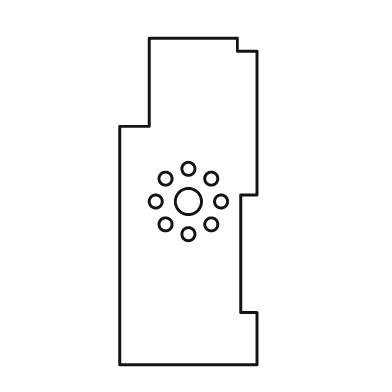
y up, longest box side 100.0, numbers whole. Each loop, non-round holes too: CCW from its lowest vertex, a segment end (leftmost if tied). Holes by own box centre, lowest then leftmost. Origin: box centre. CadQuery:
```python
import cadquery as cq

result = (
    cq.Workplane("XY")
    .moveTo(-21.0, -50.0)
    .lineTo(21.0, -50.0)
    .lineTo(21.0, -34.0)
    .lineTo(16.0, -34.0)
    .lineTo(16.0, 2.0)
    .lineTo(21.0, 2.0)
    .lineTo(21.0, 46.0)
    .lineTo(15.0, 46.0)
    .lineTo(15.0, 50.0)
    .lineTo(-12.0, 50.0)
    .lineTo(-12.0, 23.0)
    .lineTo(-21.0, 23.0)
    .close()
    .moveTo(0.0, -10.0)
    .circle(2.0)
    .moveTo(-7.0, -7.0)
    .circle(2.0)
    .moveTo(7.0, -7.0)
    .circle(2.0)
    .moveTo(-10.0, 0.0)
    .circle(2.0)
    .moveTo(0.0, 0.0)
    .circle(4.0)
    .moveTo(10.0, 0.0)
    .circle(2.0)
    .moveTo(-7.0, 7.0)
    .circle(2.0)
    .moveTo(7.0, 7.0)
    .circle(2.0)
    .moveTo(0.0, 10.0)
    .circle(2.0)
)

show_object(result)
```